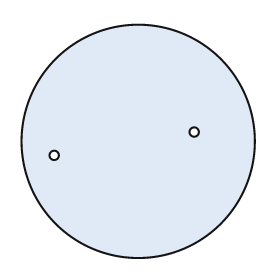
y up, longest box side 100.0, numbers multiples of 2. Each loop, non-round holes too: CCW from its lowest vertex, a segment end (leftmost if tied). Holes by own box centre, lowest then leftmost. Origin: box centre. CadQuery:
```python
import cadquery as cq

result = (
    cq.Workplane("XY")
    .moveTo(0.0, 0.0)
    .circle(50.0)
    .moveTo(-36.0, -6.0)
    .circle(2.0)
    .moveTo(24.0, 4.0)
    .circle(2.0)
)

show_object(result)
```